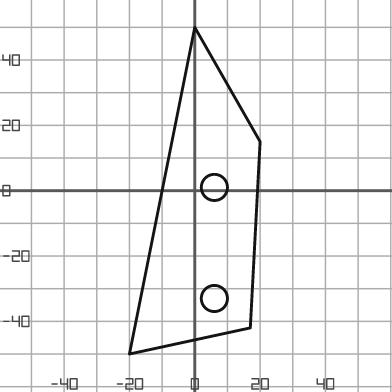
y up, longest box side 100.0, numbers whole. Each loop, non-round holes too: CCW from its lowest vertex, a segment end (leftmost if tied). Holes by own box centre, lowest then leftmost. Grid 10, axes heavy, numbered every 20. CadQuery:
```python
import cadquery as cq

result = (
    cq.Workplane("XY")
    .moveTo(-20.0, -50.0)
    .lineTo(17.0, -42.0)
    .lineTo(20.0, 15.0)
    .lineTo(0.0, 50.0)
    .close()
    .moveTo(6.0, -33.0)
    .circle(4.0)
    .moveTo(6.0, 1.0)
    .circle(4.0)
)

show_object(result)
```